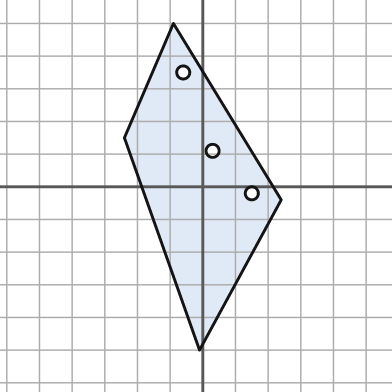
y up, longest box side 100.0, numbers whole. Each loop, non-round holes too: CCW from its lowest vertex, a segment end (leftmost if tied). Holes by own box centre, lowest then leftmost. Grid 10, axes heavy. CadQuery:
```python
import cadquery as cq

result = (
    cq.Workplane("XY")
    .moveTo(-1.0, -50.0)
    .lineTo(24.0, -4.0)
    .lineTo(-9.0, 50.0)
    .lineTo(-24.0, 15.0)
    .close()
    .moveTo(15.0, -2.0)
    .circle(2.0)
    .moveTo(3.0, 11.0)
    .circle(2.0)
    .moveTo(-6.0, 35.0)
    .circle(2.0)
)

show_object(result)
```